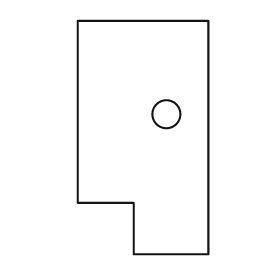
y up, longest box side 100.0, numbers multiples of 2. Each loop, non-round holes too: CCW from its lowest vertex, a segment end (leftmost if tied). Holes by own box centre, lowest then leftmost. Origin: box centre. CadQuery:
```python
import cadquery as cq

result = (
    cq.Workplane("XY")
    .moveTo(-4.0, -50.0)
    .lineTo(28.0, -50.0)
    .lineTo(28.0, 50.0)
    .lineTo(-28.0, 50.0)
    .lineTo(-28.0, -28.0)
    .lineTo(-4.0, -28.0)
    .close()
    .moveTo(10.0, 10.0)
    .circle(6.0)
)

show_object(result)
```